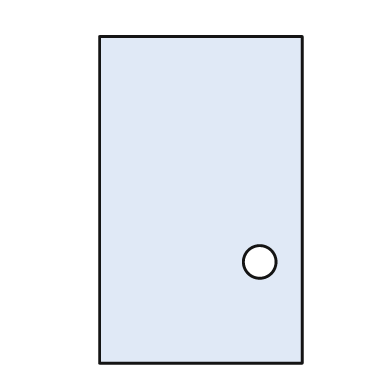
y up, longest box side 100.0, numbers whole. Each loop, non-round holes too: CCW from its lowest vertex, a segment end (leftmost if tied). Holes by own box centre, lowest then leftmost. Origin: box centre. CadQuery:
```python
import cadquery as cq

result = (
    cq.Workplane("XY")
    .moveTo(-31.0, -50.0)
    .lineTo(31.0, -50.0)
    .lineTo(31.0, 50.0)
    .lineTo(-31.0, 50.0)
    .close()
    .moveTo(18.0, -19.0)
    .circle(5.0)
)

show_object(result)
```